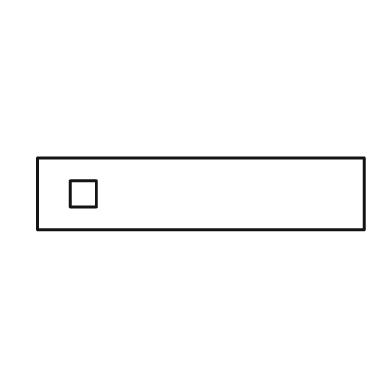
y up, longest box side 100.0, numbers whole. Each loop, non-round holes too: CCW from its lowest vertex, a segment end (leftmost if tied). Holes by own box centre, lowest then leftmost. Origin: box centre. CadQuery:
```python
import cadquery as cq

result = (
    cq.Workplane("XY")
    .moveTo(-50.0, -11.0)
    .lineTo(50.0, -11.0)
    .lineTo(50.0, 11.0)
    .lineTo(-50.0, 11.0)
    .close()
    .moveTo(-40.0, -4.0)
    .lineTo(-32.0, -4.0)
    .lineTo(-32.0, 4.0)
    .lineTo(-40.0, 4.0)
    .close()
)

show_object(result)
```